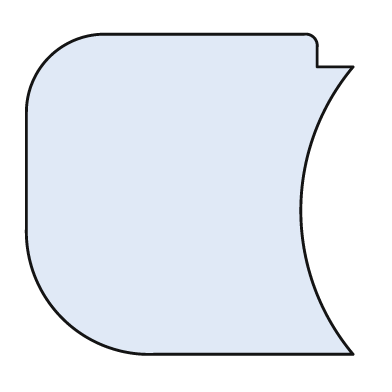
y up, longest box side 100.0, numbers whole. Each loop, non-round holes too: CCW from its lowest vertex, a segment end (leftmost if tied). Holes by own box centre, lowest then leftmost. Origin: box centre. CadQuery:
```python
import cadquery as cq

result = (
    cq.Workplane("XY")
    .moveTo(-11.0, -49.0)
    .lineTo(50.0, -49.0)
    .threePointArc((34.0, -5.0), (50.0, 39.0))
    .lineTo(39.0, 39.0)
    .lineTo(39.0, 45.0)
    .threePointArc((38.0, 48.0), (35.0, 49.0))
    .lineTo(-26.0, 49.0)
    .threePointArc((-43.0, 42.0), (-50.0, 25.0))
    .lineTo(-50.0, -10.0)
    .threePointArc((-39.0, -38.0), (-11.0, -49.0))
    .close()
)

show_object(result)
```